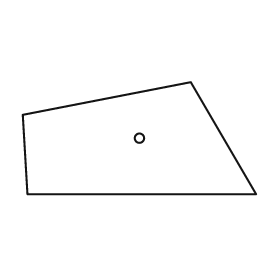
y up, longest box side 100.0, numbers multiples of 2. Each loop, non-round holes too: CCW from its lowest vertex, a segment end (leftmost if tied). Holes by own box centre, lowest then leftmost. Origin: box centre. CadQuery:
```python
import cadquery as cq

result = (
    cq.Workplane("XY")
    .moveTo(-48.0, -24.0)
    .lineTo(50.0, -24.0)
    .lineTo(22.0, 24.0)
    .lineTo(-50.0, 10.0)
    .close()
    .moveTo(0.0, 0.0)
    .circle(2.0)
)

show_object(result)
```